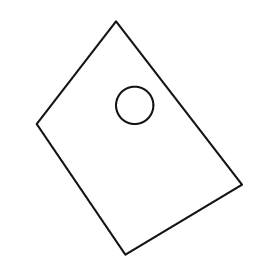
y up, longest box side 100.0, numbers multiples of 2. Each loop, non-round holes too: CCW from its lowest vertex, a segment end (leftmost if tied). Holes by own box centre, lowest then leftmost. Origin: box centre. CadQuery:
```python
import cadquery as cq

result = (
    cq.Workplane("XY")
    .moveTo(-6.0, -50.0)
    .lineTo(44.0, -20.0)
    .lineTo(-10.0, 50.0)
    .lineTo(-44.0, 6.0)
    .close()
    .moveTo(-2.0, 14.0)
    .circle(8.0)
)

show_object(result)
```